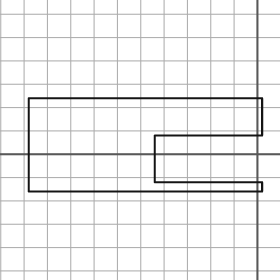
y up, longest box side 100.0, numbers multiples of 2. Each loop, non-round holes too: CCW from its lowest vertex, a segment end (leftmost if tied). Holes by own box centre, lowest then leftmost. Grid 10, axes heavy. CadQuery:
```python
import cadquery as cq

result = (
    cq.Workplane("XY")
    .moveTo(-98.0, -16.0)
    .lineTo(2.0, -16.0)
    .lineTo(2.0, -12.0)
    .lineTo(-44.0, -12.0)
    .lineTo(-44.0, 8.0)
    .lineTo(2.0, 8.0)
    .lineTo(2.0, 24.0)
    .lineTo(-98.0, 24.0)
    .close()
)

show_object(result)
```